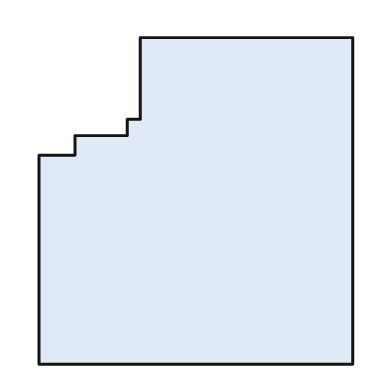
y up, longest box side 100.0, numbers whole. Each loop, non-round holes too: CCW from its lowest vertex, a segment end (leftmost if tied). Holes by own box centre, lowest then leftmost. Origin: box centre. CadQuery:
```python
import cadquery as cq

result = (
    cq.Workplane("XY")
    .moveTo(-48.0, -50.0)
    .lineTo(48.0, -50.0)
    .lineTo(48.0, 50.0)
    .lineTo(-17.0, 50.0)
    .lineTo(-17.0, 25.0)
    .lineTo(-21.0, 25.0)
    .lineTo(-21.0, 20.0)
    .lineTo(-37.0, 20.0)
    .lineTo(-37.0, 14.0)
    .lineTo(-48.0, 14.0)
    .close()
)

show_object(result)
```